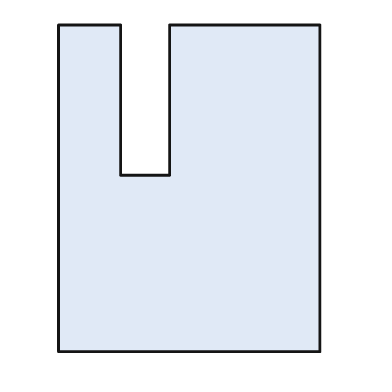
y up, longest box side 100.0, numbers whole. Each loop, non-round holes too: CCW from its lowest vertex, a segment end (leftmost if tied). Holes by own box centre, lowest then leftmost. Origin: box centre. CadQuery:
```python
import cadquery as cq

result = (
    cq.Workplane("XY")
    .moveTo(-40.0, -50.0)
    .lineTo(40.0, -50.0)
    .lineTo(40.0, 50.0)
    .lineTo(-6.0, 50.0)
    .lineTo(-6.0, 4.0)
    .lineTo(-21.0, 4.0)
    .lineTo(-21.0, 50.0)
    .lineTo(-40.0, 50.0)
    .close()
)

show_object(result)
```